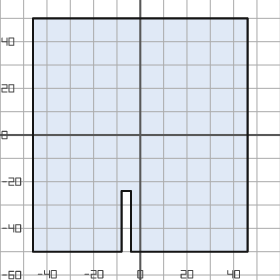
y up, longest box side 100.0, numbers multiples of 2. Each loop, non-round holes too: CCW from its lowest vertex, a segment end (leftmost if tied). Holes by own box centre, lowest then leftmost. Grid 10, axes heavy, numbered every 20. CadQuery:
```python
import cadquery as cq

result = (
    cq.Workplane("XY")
    .moveTo(-46.0, -50.0)
    .lineTo(-8.0, -50.0)
    .lineTo(-8.0, -24.0)
    .lineTo(-4.0, -24.0)
    .lineTo(-4.0, -50.0)
    .lineTo(46.0, -50.0)
    .lineTo(46.0, 50.0)
    .lineTo(-46.0, 50.0)
    .close()
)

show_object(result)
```